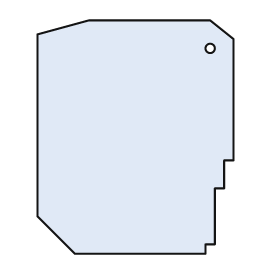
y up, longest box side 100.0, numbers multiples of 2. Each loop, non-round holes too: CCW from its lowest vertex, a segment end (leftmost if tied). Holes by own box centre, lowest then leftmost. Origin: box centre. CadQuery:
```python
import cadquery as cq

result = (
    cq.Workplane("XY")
    .moveTo(-26.0, -50.0)
    .lineTo(30.0, -50.0)
    .lineTo(30.0, -46.0)
    .lineTo(34.0, -46.0)
    .lineTo(34.0, -22.0)
    .lineTo(38.0, -22.0)
    .lineTo(38.0, -10.0)
    .lineTo(42.0, -10.0)
    .lineTo(42.0, 42.0)
    .lineTo(32.0, 50.0)
    .lineTo(-20.0, 50.0)
    .lineTo(-42.0, 44.0)
    .lineTo(-42.0, -34.0)
    .close()
    .moveTo(32.0, 38.0)
    .circle(2.0)
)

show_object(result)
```